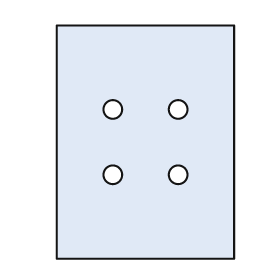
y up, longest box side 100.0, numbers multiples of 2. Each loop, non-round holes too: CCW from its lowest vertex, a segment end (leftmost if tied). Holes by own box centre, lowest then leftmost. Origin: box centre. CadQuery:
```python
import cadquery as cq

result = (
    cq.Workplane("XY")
    .moveTo(-38.0, -50.0)
    .lineTo(38.0, -50.0)
    .lineTo(38.0, 50.0)
    .lineTo(-38.0, 50.0)
    .close()
    .moveTo(-14.0, -14.0)
    .circle(4.0)
    .moveTo(14.0, -14.0)
    .circle(4.0)
    .moveTo(-14.0, 14.0)
    .circle(4.0)
    .moveTo(14.0, 14.0)
    .circle(4.0)
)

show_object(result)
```